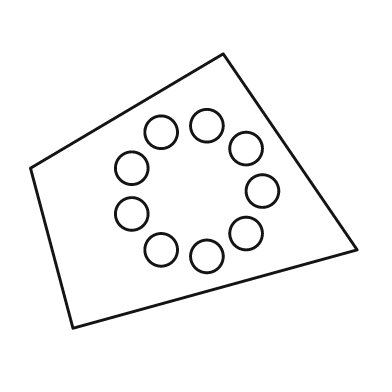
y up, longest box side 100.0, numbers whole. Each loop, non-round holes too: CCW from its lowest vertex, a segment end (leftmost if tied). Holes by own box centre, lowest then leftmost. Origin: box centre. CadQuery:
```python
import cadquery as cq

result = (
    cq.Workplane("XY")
    .moveTo(-37.0, -42.0)
    .lineTo(50.0, -18.0)
    .lineTo(9.0, 42.0)
    .lineTo(-50.0, 7.0)
    .close()
    .moveTo(4.0, -20.0)
    .circle(5.0)
    .moveTo(-10.0, -18.0)
    .circle(5.0)
    .moveTo(16.0, -13.0)
    .circle(5.0)
    .moveTo(-19.0, -7.0)
    .circle(5.0)
    .moveTo(21.0, 0.0)
    .circle(5.0)
    .moveTo(-19.0, 7.0)
    .circle(5.0)
    .moveTo(16.0, 13.0)
    .circle(5.0)
    .moveTo(-10.0, 18.0)
    .circle(5.0)
    .moveTo(4.0, 20.0)
    .circle(5.0)
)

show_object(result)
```